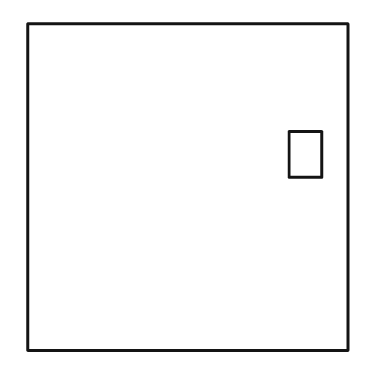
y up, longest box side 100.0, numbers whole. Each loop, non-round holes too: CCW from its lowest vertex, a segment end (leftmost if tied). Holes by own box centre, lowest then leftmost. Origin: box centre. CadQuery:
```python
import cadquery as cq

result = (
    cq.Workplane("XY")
    .moveTo(-49.0, -50.0)
    .lineTo(49.0, -50.0)
    .lineTo(49.0, 50.0)
    .lineTo(-49.0, 50.0)
    .close()
    .moveTo(31.0, 3.0)
    .lineTo(41.0, 3.0)
    .lineTo(41.0, 17.0)
    .lineTo(31.0, 17.0)
    .close()
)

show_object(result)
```